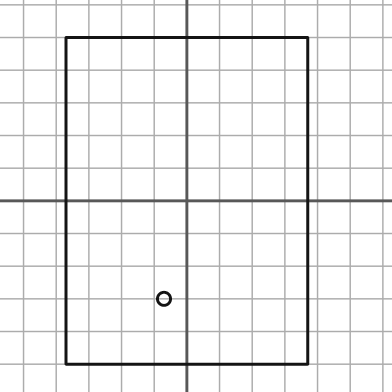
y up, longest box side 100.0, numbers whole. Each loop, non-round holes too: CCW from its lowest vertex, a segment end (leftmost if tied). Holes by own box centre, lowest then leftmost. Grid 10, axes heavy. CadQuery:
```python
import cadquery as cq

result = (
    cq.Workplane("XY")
    .moveTo(-37.0, -50.0)
    .lineTo(37.0, -50.0)
    .lineTo(37.0, 50.0)
    .lineTo(-37.0, 50.0)
    .close()
    .moveTo(-7.0, -30.0)
    .circle(2.0)
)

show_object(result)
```